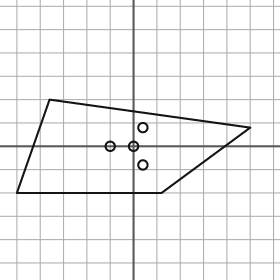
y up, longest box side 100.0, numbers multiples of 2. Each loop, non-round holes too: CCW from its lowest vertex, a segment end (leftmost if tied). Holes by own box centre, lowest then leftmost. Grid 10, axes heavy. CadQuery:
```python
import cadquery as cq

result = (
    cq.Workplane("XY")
    .moveTo(-50.0, -20.0)
    .lineTo(12.0, -20.0)
    .lineTo(50.0, 8.0)
    .lineTo(-36.0, 20.0)
    .close()
    .moveTo(4.0, -8.0)
    .circle(2.0)
    .moveTo(-10.0, 0.0)
    .circle(2.0)
    .moveTo(0.0, 0.0)
    .circle(2.0)
    .moveTo(4.0, 8.0)
    .circle(2.0)
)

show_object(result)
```